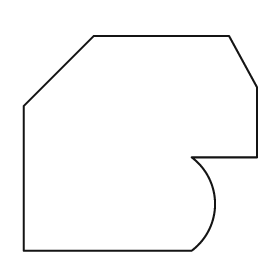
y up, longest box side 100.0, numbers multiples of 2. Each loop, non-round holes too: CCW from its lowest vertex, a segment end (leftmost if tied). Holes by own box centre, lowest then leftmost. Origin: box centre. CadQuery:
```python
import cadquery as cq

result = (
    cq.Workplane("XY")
    .moveTo(-50.0, -46.0)
    .lineTo(22.0, -46.0)
    .threePointArc((32.0, -26.0), (22.0, -6.0))
    .lineTo(50.0, -6.0)
    .lineTo(50.0, 24.0)
    .lineTo(38.0, 46.0)
    .lineTo(-20.0, 46.0)
    .lineTo(-50.0, 16.0)
    .close()
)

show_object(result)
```